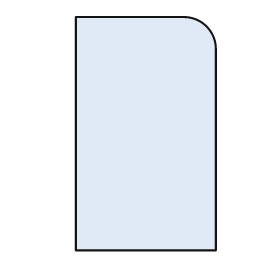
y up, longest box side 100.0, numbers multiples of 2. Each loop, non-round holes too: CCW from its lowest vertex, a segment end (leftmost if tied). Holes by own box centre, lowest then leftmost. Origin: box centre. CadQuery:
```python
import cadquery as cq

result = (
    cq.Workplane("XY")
    .moveTo(-30.0, -50.0)
    .lineTo(30.0, -50.0)
    .lineTo(30.0, 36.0)
    .threePointArc((26.0, 46.0), (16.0, 50.0))
    .lineTo(-30.0, 50.0)
    .close()
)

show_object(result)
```